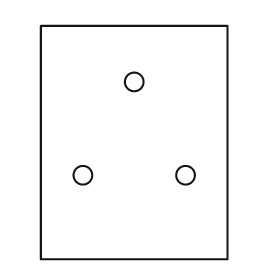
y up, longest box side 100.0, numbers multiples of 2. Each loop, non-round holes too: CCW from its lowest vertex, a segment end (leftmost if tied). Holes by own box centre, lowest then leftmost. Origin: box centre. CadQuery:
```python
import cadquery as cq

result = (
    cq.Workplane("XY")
    .moveTo(-40.0, -50.0)
    .lineTo(40.0, -50.0)
    .lineTo(40.0, 50.0)
    .lineTo(-40.0, 50.0)
    .close()
    .moveTo(-22.0, -14.0)
    .circle(4.0)
    .moveTo(22.0, -14.0)
    .circle(4.0)
    .moveTo(0.0, 26.0)
    .circle(4.0)
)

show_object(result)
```